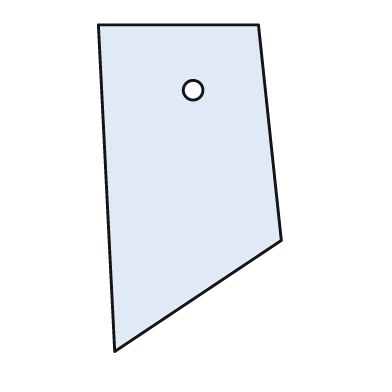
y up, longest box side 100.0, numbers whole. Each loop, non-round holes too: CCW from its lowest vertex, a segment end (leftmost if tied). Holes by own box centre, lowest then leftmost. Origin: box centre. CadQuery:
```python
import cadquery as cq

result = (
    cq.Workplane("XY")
    .moveTo(-23.0, -50.0)
    .lineTo(28.0, -16.0)
    .lineTo(21.0, 50.0)
    .lineTo(-28.0, 50.0)
    .close()
    .moveTo(1.0, 30.0)
    .circle(3.0)
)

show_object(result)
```